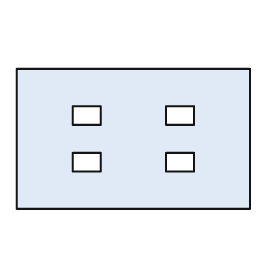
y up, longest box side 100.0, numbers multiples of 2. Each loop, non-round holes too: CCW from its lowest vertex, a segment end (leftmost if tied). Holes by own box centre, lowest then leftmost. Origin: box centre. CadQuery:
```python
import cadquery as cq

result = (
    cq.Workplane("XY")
    .moveTo(-50.0, -30.0)
    .lineTo(50.0, -30.0)
    .lineTo(50.0, 30.0)
    .lineTo(-50.0, 30.0)
    .close()
    .moveTo(-26.0, -14.0)
    .lineTo(-14.0, -14.0)
    .lineTo(-14.0, -6.0)
    .lineTo(-26.0, -6.0)
    .close()
    .moveTo(14.0, -14.0)
    .lineTo(26.0, -14.0)
    .lineTo(26.0, -6.0)
    .lineTo(14.0, -6.0)
    .close()
    .moveTo(-26.0, 6.0)
    .lineTo(-14.0, 6.0)
    .lineTo(-14.0, 14.0)
    .lineTo(-26.0, 14.0)
    .close()
    .moveTo(14.0, 6.0)
    .lineTo(26.0, 6.0)
    .lineTo(26.0, 14.0)
    .lineTo(14.0, 14.0)
    .close()
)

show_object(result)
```